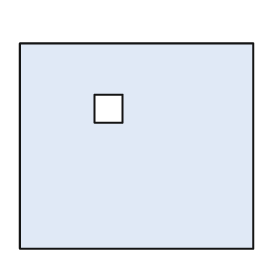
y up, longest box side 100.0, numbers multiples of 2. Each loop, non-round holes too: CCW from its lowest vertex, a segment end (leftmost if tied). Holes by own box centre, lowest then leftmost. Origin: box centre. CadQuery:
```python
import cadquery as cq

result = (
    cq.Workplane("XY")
    .moveTo(-50.0, -44.0)
    .lineTo(50.0, -44.0)
    .lineTo(50.0, 44.0)
    .lineTo(-50.0, 44.0)
    .close()
    .moveTo(-18.0, 10.0)
    .lineTo(-6.0, 10.0)
    .lineTo(-6.0, 22.0)
    .lineTo(-18.0, 22.0)
    .close()
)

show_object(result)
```